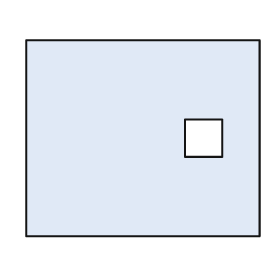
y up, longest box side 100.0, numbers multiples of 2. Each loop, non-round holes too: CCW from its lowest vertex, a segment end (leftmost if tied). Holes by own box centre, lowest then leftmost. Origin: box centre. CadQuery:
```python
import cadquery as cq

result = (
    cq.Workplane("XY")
    .moveTo(-50.0, -42.0)
    .lineTo(50.0, -42.0)
    .lineTo(50.0, 42.0)
    .lineTo(-50.0, 42.0)
    .close()
    .moveTo(18.0, -8.0)
    .lineTo(34.0, -8.0)
    .lineTo(34.0, 8.0)
    .lineTo(18.0, 8.0)
    .close()
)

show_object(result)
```